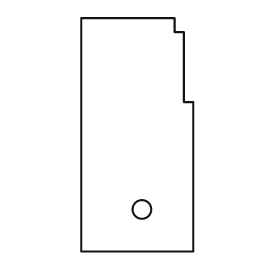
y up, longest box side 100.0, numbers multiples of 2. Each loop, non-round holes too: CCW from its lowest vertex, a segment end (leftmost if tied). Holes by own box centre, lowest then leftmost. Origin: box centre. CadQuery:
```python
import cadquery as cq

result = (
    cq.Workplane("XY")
    .moveTo(-24.0, -50.0)
    .lineTo(24.0, -50.0)
    .lineTo(24.0, 14.0)
    .lineTo(20.0, 14.0)
    .lineTo(20.0, 44.0)
    .lineTo(16.0, 44.0)
    .lineTo(16.0, 50.0)
    .lineTo(-24.0, 50.0)
    .close()
    .moveTo(2.0, -32.0)
    .circle(4.0)
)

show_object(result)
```